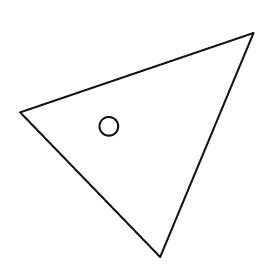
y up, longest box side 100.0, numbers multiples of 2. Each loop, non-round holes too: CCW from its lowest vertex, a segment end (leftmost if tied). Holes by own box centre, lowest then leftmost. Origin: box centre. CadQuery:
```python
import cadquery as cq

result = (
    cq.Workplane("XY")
    .moveTo(10.0, -48.0)
    .lineTo(50.0, 48.0)
    .lineTo(-50.0, 14.0)
    .close()
    .moveTo(-12.0, 8.0)
    .circle(4.0)
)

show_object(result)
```